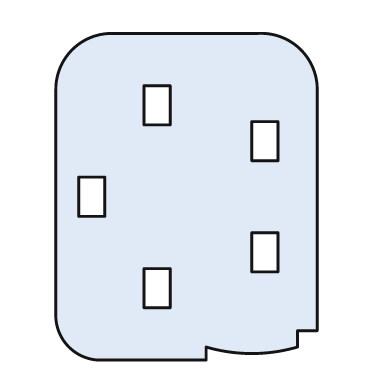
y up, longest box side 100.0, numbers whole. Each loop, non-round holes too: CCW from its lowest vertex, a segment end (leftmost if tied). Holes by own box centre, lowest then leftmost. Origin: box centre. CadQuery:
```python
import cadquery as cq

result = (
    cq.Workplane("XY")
    .moveTo(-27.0, -50.0)
    .lineTo(6.0, -50.0)
    .lineTo(6.0, -46.0)
    .threePointArc((20.0, -48.0), (34.0, -46.0))
    .lineTo(34.0, -41.0)
    .lineTo(40.0, -41.0)
    .lineTo(40.0, 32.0)
    .threePointArc((35.0, 45.0), (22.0, 50.0))
    .lineTo(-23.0, 50.0)
    .threePointArc((-35.0, 45.0), (-40.0, 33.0))
    .lineTo(-40.0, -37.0)
    .threePointArc((-36.0, -46.0), (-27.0, -50.0))
    .close()
    .moveTo(-13.0, -34.0)
    .lineTo(-5.0, -34.0)
    .lineTo(-5.0, -22.0)
    .lineTo(-13.0, -22.0)
    .close()
    .moveTo(20.0, -23.0)
    .lineTo(28.0, -23.0)
    .lineTo(28.0, -11.0)
    .lineTo(20.0, -11.0)
    .close()
    .moveTo(-33.0, -6.0)
    .lineTo(-25.0, -6.0)
    .lineTo(-25.0, 6.0)
    .lineTo(-33.0, 6.0)
    .close()
    .moveTo(20.0, 11.0)
    .lineTo(28.0, 11.0)
    .lineTo(28.0, 23.0)
    .lineTo(20.0, 23.0)
    .close()
    .moveTo(-13.0, 22.0)
    .lineTo(-5.0, 22.0)
    .lineTo(-5.0, 34.0)
    .lineTo(-13.0, 34.0)
    .close()
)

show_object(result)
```